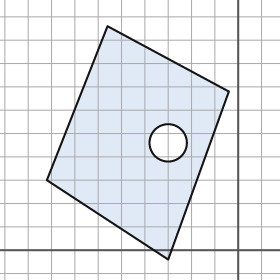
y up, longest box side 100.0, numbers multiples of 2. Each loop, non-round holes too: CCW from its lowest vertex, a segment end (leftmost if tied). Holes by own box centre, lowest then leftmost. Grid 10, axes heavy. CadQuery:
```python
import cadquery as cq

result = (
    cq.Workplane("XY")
    .moveTo(-30.0, -4.0)
    .lineTo(-4.0, 68.0)
    .lineTo(-56.0, 96.0)
    .lineTo(-82.0, 30.0)
    .close()
    .moveTo(-30.0, 46.0)
    .circle(8.0)
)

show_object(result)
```